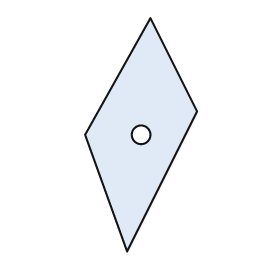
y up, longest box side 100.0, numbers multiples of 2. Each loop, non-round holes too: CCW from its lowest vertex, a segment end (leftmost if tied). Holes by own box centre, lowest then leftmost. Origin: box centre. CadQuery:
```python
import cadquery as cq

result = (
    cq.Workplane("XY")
    .moveTo(-6.0, -50.0)
    .lineTo(24.0, 10.0)
    .lineTo(4.0, 50.0)
    .lineTo(-24.0, 0.0)
    .close()
    .moveTo(0.0, 0.0)
    .circle(4.0)
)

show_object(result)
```